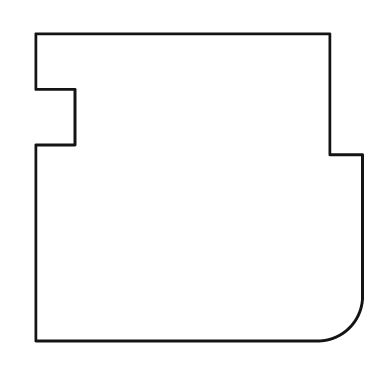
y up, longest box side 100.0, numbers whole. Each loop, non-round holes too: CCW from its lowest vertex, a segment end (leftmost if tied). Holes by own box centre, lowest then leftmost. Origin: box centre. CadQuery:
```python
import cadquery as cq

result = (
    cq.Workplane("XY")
    .moveTo(-50.0, -47.0)
    .lineTo(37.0, -47.0)
    .threePointArc((46.0, -43.0), (50.0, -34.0))
    .lineTo(50.0, 10.0)
    .lineTo(40.0, 10.0)
    .lineTo(40.0, 47.0)
    .lineTo(-50.0, 47.0)
    .lineTo(-50.0, 30.0)
    .lineTo(-38.0, 30.0)
    .lineTo(-38.0, 13.0)
    .lineTo(-50.0, 13.0)
    .close()
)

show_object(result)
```